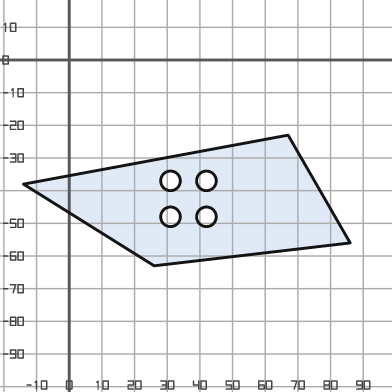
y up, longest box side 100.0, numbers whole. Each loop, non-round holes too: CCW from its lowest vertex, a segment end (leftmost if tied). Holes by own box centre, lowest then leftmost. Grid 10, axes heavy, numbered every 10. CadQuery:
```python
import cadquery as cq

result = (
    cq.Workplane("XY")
    .moveTo(26.0, -63.0)
    .lineTo(86.0, -56.0)
    .lineTo(67.0, -23.0)
    .lineTo(-14.0, -38.0)
    .close()
    .moveTo(31.0, -48.0)
    .circle(3.0)
    .moveTo(42.0, -48.0)
    .circle(3.0)
    .moveTo(31.0, -37.0)
    .circle(3.0)
    .moveTo(42.0, -37.0)
    .circle(3.0)
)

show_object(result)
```